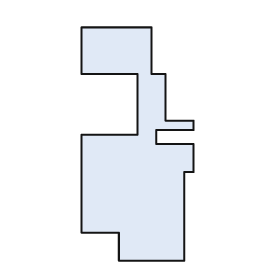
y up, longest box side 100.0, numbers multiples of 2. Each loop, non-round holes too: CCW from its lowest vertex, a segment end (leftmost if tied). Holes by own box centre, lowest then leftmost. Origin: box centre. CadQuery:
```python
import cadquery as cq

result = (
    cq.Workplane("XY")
    .moveTo(-8.0, -50.0)
    .lineTo(20.0, -50.0)
    .lineTo(20.0, -12.0)
    .lineTo(24.0, -12.0)
    .lineTo(24.0, 0.0)
    .lineTo(8.0, 0.0)
    .lineTo(8.0, 6.0)
    .lineTo(24.0, 6.0)
    .lineTo(24.0, 10.0)
    .lineTo(12.0, 10.0)
    .lineTo(12.0, 30.0)
    .lineTo(6.0, 30.0)
    .lineTo(6.0, 50.0)
    .lineTo(-24.0, 50.0)
    .lineTo(-24.0, 30.0)
    .lineTo(0.0, 30.0)
    .lineTo(0.0, 4.0)
    .lineTo(-24.0, 4.0)
    .lineTo(-24.0, -38.0)
    .lineTo(-8.0, -38.0)
    .close()
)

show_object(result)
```